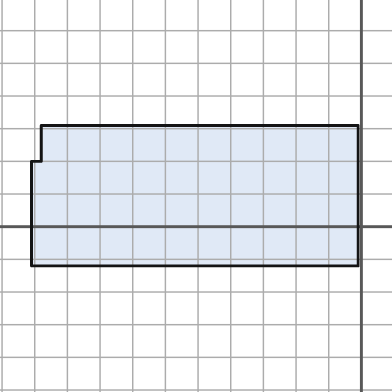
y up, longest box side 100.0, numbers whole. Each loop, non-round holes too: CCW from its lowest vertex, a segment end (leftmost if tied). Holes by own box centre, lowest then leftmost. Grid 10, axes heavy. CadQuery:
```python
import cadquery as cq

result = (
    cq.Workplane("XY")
    .moveTo(-101.0, -12.0)
    .lineTo(-1.0, -12.0)
    .lineTo(-1.0, 31.0)
    .lineTo(-98.0, 31.0)
    .lineTo(-98.0, 20.0)
    .lineTo(-101.0, 20.0)
    .close()
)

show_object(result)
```